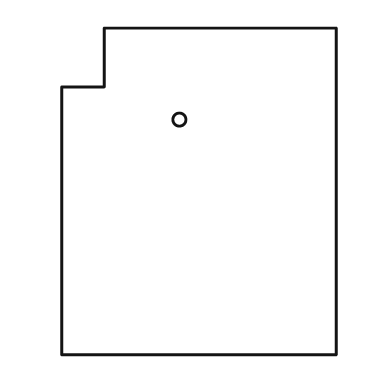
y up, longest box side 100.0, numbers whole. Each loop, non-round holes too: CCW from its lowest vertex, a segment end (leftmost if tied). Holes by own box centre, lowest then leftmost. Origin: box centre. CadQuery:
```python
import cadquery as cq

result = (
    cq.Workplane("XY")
    .moveTo(-42.0, -50.0)
    .lineTo(42.0, -50.0)
    .lineTo(42.0, 50.0)
    .lineTo(-29.0, 50.0)
    .lineTo(-29.0, 32.0)
    .lineTo(-42.0, 32.0)
    .close()
    .moveTo(-6.0, 22.0)
    .circle(2.0)
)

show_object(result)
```